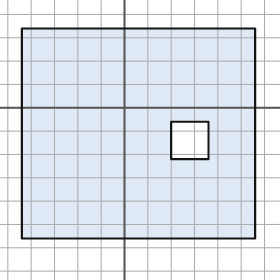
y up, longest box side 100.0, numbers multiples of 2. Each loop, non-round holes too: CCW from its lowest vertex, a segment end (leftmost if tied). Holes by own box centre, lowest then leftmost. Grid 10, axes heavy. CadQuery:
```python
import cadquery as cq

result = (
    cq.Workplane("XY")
    .moveTo(-44.0, -56.0)
    .lineTo(56.0, -56.0)
    .lineTo(56.0, 34.0)
    .lineTo(-44.0, 34.0)
    .close()
    .moveTo(20.0, -22.0)
    .lineTo(36.0, -22.0)
    .lineTo(36.0, -6.0)
    .lineTo(20.0, -6.0)
    .close()
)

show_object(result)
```